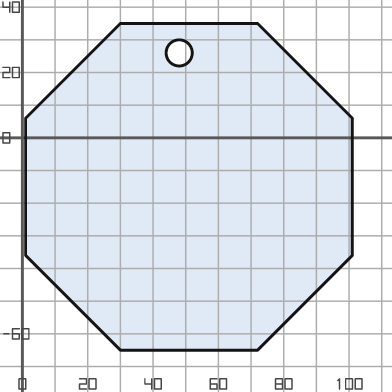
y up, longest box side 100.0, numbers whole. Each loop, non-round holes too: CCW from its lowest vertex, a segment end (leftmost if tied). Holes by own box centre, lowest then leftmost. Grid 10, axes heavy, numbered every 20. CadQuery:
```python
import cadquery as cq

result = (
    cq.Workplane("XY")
    .moveTo(30.0, -65.0)
    .lineTo(72.0, -65.0)
    .lineTo(101.0, -36.0)
    .lineTo(101.0, 6.0)
    .lineTo(72.0, 35.0)
    .lineTo(30.0, 35.0)
    .lineTo(1.0, 6.0)
    .lineTo(1.0, -36.0)
    .close()
    .moveTo(48.0, 26.0)
    .circle(4.0)
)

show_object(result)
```